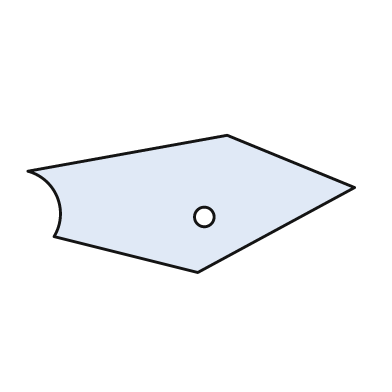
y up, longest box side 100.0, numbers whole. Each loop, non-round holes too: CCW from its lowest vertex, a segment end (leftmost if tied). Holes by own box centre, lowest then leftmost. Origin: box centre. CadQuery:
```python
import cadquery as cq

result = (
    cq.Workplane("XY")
    .moveTo(2.0, -21.0)
    .lineTo(50.0, 5.0)
    .lineTo(11.0, 21.0)
    .lineTo(-50.0, 10.0)
    .threePointArc((-41.0, 2.0), (-42.0, -10.0))
    .close()
    .moveTo(4.0, -4.0)
    .circle(3.0)
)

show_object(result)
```